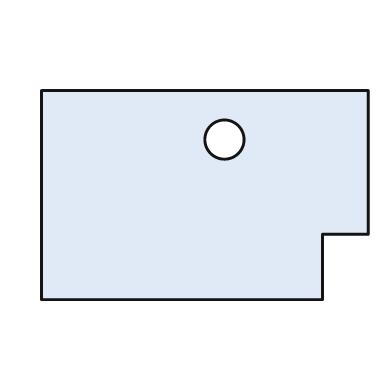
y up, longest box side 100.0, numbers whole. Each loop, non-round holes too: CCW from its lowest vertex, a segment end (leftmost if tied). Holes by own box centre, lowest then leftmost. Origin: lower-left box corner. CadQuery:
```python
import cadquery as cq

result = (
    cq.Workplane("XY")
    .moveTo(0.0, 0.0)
    .lineTo(86.0, 0.0)
    .lineTo(86.0, 20.0)
    .lineTo(100.0, 20.0)
    .lineTo(100.0, 64.0)
    .lineTo(0.0, 64.0)
    .close()
    .moveTo(56.0, 49.0)
    .circle(6.0)
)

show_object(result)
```